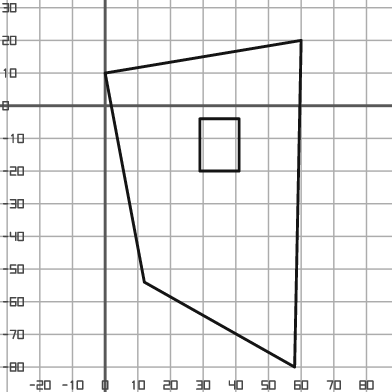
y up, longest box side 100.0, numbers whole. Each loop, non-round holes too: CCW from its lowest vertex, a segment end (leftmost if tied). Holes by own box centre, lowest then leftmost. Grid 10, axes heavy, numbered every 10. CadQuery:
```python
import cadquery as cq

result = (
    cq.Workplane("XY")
    .moveTo(58.0, -80.0)
    .lineTo(60.0, 20.0)
    .lineTo(0.0, 10.0)
    .lineTo(12.0, -54.0)
    .close()
    .moveTo(29.0, -20.0)
    .lineTo(41.0, -20.0)
    .lineTo(41.0, -4.0)
    .lineTo(29.0, -4.0)
    .close()
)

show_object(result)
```